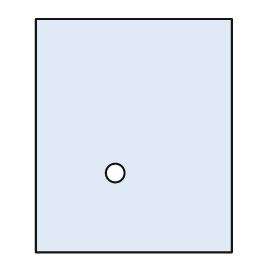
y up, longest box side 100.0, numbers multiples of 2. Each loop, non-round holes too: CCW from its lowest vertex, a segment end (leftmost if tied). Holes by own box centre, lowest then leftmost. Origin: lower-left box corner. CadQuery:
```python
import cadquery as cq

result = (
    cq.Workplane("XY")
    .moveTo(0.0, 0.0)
    .lineTo(84.0, 0.0)
    .lineTo(84.0, 100.0)
    .lineTo(0.0, 100.0)
    .close()
    .moveTo(34.0, 34.0)
    .circle(4.0)
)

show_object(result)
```